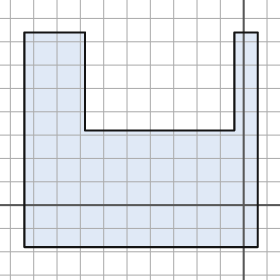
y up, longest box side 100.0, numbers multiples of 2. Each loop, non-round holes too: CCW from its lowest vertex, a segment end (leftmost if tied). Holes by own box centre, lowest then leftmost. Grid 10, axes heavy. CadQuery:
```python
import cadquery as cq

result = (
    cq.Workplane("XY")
    .moveTo(-94.0, -18.0)
    .lineTo(6.0, -18.0)
    .lineTo(6.0, 74.0)
    .lineTo(-4.0, 74.0)
    .lineTo(-4.0, 32.0)
    .lineTo(-68.0, 32.0)
    .lineTo(-68.0, 74.0)
    .lineTo(-94.0, 74.0)
    .close()
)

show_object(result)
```